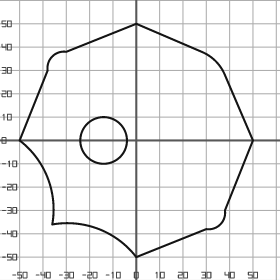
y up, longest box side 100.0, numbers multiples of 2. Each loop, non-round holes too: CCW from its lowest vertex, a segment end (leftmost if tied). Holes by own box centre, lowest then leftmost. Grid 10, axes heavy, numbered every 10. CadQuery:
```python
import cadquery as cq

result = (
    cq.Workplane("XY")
    .moveTo(0.0, -50.0)
    .lineTo(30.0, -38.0)
    .threePointArc((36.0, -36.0), (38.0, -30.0))
    .lineTo(50.0, 0.0)
    .lineTo(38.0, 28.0)
    .threePointArc((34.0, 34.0), (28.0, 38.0))
    .lineTo(0.0, 50.0)
    .lineTo(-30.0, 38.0)
    .threePointArc((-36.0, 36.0), (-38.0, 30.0))
    .lineTo(-50.0, 0.0)
    .threePointArc((-38.0, -16.0), (-36.0, -36.0))
    .threePointArc((-16.0, -38.0), (0.0, -50.0))
    .close()
    .moveTo(-14.0, 0.0)
    .circle(10.0)
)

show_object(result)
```